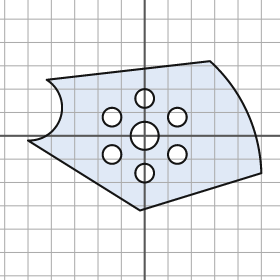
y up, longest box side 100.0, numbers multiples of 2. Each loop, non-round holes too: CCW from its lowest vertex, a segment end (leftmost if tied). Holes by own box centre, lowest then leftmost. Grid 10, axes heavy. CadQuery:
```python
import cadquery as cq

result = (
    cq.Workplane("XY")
    .moveTo(-2.0, -32.0)
    .lineTo(50.0, -16.0)
    .threePointArc((44.0, 10.0), (28.0, 32.0))
    .lineTo(-42.0, 24.0)
    .threePointArc((-36.0, 8.0), (-50.0, -2.0))
    .close()
    .moveTo(0.0, -16.0)
    .circle(4.0)
    .moveTo(-14.0, -8.0)
    .circle(4.0)
    .moveTo(14.0, -8.0)
    .circle(4.0)
    .moveTo(0.0, 0.0)
    .circle(6.0)
    .moveTo(-14.0, 8.0)
    .circle(4.0)
    .moveTo(14.0, 8.0)
    .circle(4.0)
    .moveTo(0.0, 16.0)
    .circle(4.0)
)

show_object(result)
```